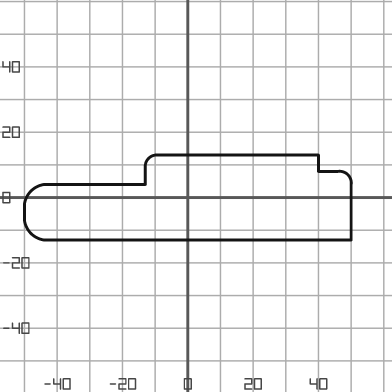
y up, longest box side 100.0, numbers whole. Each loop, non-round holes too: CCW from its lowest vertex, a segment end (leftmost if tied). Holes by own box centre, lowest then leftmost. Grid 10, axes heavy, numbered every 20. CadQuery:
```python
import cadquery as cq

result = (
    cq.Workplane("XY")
    .moveTo(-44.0, -13.0)
    .lineTo(50.0, -13.0)
    .lineTo(50.0, 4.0)
    .threePointArc((49.0, 7.0), (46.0, 8.0))
    .lineTo(40.0, 8.0)
    .lineTo(40.0, 13.0)
    .lineTo(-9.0, 13.0)
    .threePointArc((-12.0, 12.0), (-13.0, 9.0))
    .lineTo(-13.0, 4.0)
    .lineTo(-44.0, 4.0)
    .threePointArc((-48.0, 2.0), (-50.0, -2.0))
    .lineTo(-50.0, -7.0)
    .threePointArc((-48.0, -11.0), (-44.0, -13.0))
    .close()
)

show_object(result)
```